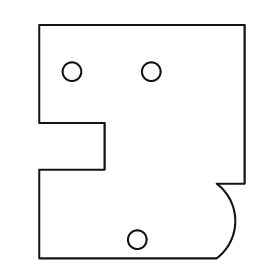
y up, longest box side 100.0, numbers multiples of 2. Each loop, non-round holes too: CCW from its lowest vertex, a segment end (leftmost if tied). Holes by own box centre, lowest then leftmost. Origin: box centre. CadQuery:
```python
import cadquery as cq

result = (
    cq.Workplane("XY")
    .moveTo(-44.0, -50.0)
    .lineTo(32.0, -50.0)
    .threePointArc((40.0, -34.0), (32.0, -18.0))
    .lineTo(44.0, -18.0)
    .lineTo(44.0, 50.0)
    .lineTo(-44.0, 50.0)
    .lineTo(-44.0, 8.0)
    .lineTo(-16.0, 8.0)
    .lineTo(-16.0, -12.0)
    .lineTo(-44.0, -12.0)
    .close()
    .moveTo(-2.0, -42.0)
    .circle(4.0)
    .moveTo(-30.0, 30.0)
    .circle(4.0)
    .moveTo(4.0, 30.0)
    .circle(4.0)
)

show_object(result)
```